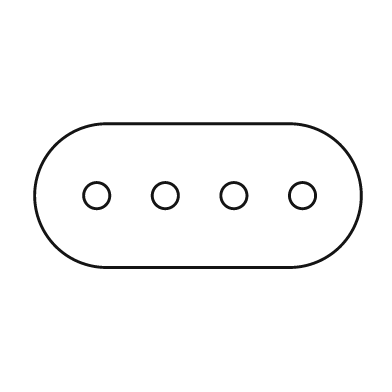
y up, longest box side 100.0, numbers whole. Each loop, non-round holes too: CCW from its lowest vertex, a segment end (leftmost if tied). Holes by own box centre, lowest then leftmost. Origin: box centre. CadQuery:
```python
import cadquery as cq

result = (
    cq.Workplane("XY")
    .moveTo(-28.0, -22.0)
    .lineTo(28.0, -22.0)
    .threePointArc((50.0, 0.0), (28.0, 22.0))
    .lineTo(-28.0, 22.0)
    .threePointArc((-50.0, 0.0), (-28.0, -22.0))
    .close()
    .moveTo(-31.0, 0.0)
    .circle(4.0)
    .moveTo(-10.0, 0.0)
    .circle(4.0)
    .moveTo(11.0, 0.0)
    .circle(4.0)
    .moveTo(32.0, 0.0)
    .circle(4.0)
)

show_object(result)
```